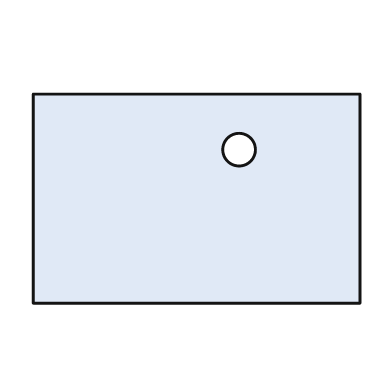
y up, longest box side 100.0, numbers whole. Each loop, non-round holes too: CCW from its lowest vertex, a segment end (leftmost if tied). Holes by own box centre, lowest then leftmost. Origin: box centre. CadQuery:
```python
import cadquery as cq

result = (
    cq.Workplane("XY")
    .moveTo(-50.0, -32.0)
    .lineTo(50.0, -32.0)
    .lineTo(50.0, 32.0)
    .lineTo(-50.0, 32.0)
    .close()
    .moveTo(13.0, 15.0)
    .circle(5.0)
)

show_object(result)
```